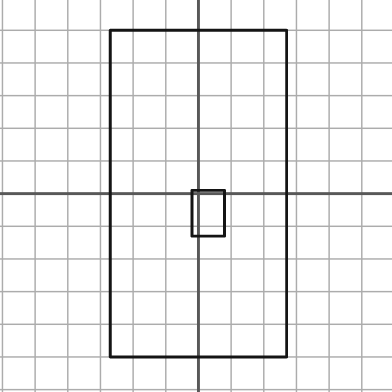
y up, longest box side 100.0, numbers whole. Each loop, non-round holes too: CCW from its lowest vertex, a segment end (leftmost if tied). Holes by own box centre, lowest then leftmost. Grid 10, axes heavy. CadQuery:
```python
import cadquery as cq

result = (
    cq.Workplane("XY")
    .moveTo(-27.0, -50.0)
    .lineTo(27.0, -50.0)
    .lineTo(27.0, 50.0)
    .lineTo(-27.0, 50.0)
    .close()
    .moveTo(-2.0, -13.0)
    .lineTo(8.0, -13.0)
    .lineTo(8.0, 1.0)
    .lineTo(-2.0, 1.0)
    .close()
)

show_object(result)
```